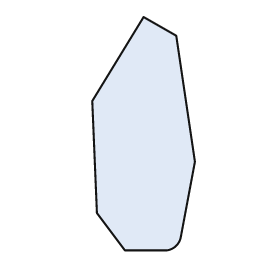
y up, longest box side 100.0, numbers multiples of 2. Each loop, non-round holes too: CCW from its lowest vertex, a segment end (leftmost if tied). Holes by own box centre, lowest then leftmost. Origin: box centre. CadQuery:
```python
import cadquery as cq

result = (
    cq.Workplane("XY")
    .moveTo(-8.0, -50.0)
    .lineTo(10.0, -50.0)
    .threePointArc((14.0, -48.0), (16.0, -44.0))
    .lineTo(22.0, -12.0)
    .lineTo(14.0, 42.0)
    .lineTo(0.0, 50.0)
    .lineTo(-22.0, 14.0)
    .lineTo(-20.0, -34.0)
    .close()
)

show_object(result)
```